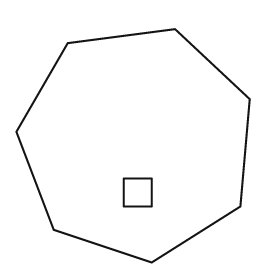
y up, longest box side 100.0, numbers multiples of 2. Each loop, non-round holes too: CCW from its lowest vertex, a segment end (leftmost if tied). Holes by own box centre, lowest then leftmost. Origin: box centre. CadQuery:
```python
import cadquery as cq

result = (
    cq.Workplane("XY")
    .moveTo(8.0, -50.0)
    .lineTo(46.0, -26.0)
    .lineTo(50.0, 20.0)
    .lineTo(18.0, 50.0)
    .lineTo(-28.0, 44.0)
    .lineTo(-50.0, 6.0)
    .lineTo(-34.0, -36.0)
    .close()
    .moveTo(-4.0, -26.0)
    .lineTo(8.0, -26.0)
    .lineTo(8.0, -14.0)
    .lineTo(-4.0, -14.0)
    .close()
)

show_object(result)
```